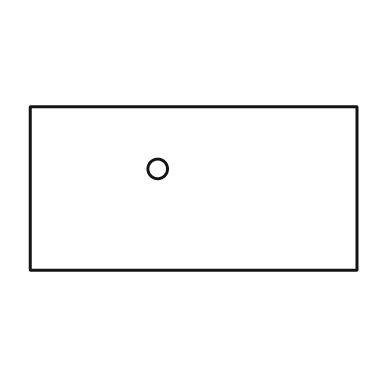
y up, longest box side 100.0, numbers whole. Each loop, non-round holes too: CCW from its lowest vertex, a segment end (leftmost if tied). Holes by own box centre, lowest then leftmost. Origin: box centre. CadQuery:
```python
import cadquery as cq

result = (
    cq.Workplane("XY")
    .moveTo(-50.0, -25.0)
    .lineTo(50.0, -25.0)
    .lineTo(50.0, 25.0)
    .lineTo(-50.0, 25.0)
    .close()
    .moveTo(-11.0, 6.0)
    .circle(3.0)
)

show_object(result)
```